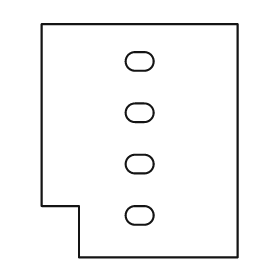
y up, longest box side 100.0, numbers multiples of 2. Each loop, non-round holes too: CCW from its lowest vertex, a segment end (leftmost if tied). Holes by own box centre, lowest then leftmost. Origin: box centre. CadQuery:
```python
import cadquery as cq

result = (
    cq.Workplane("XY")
    .moveTo(-26.0, -50.0)
    .lineTo(42.0, -50.0)
    .lineTo(42.0, 50.0)
    .lineTo(-42.0, 50.0)
    .lineTo(-42.0, -28.0)
    .lineTo(-26.0, -28.0)
    .close()
    .moveTo(-2.0, -36.0)
    .lineTo(2.0, -36.0)
    .threePointArc((6.0, -32.0), (2.0, -28.0))
    .lineTo(-2.0, -28.0)
    .threePointArc((-6.0, -32.0), (-2.0, -36.0))
    .close()
    .moveTo(-2.0, -14.0)
    .lineTo(2.0, -14.0)
    .threePointArc((6.0, -10.0), (2.0, -6.0))
    .lineTo(-2.0, -6.0)
    .threePointArc((-6.0, -10.0), (-2.0, -14.0))
    .close()
    .moveTo(-2.0, 8.0)
    .lineTo(2.0, 8.0)
    .threePointArc((6.0, 12.0), (2.0, 16.0))
    .lineTo(-2.0, 16.0)
    .threePointArc((-6.0, 12.0), (-2.0, 8.0))
    .close()
    .moveTo(-2.0, 30.0)
    .lineTo(2.0, 30.0)
    .threePointArc((6.0, 34.0), (2.0, 38.0))
    .lineTo(-2.0, 38.0)
    .threePointArc((-6.0, 34.0), (-2.0, 30.0))
    .close()
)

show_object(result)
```